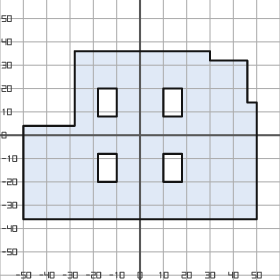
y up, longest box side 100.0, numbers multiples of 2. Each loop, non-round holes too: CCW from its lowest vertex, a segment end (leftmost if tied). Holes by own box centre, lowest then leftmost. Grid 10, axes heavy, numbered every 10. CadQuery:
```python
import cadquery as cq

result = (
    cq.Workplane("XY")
    .moveTo(-50.0, -36.0)
    .lineTo(50.0, -36.0)
    .lineTo(50.0, 14.0)
    .lineTo(46.0, 14.0)
    .lineTo(46.0, 32.0)
    .lineTo(30.0, 32.0)
    .lineTo(30.0, 36.0)
    .lineTo(-28.0, 36.0)
    .lineTo(-28.0, 4.0)
    .lineTo(-50.0, 4.0)
    .close()
    .moveTo(-18.0, -20.0)
    .lineTo(-10.0, -20.0)
    .lineTo(-10.0, -8.0)
    .lineTo(-18.0, -8.0)
    .close()
    .moveTo(10.0, -20.0)
    .lineTo(18.0, -20.0)
    .lineTo(18.0, -8.0)
    .lineTo(10.0, -8.0)
    .close()
    .moveTo(-18.0, 8.0)
    .lineTo(-10.0, 8.0)
    .lineTo(-10.0, 20.0)
    .lineTo(-18.0, 20.0)
    .close()
    .moveTo(10.0, 8.0)
    .lineTo(18.0, 8.0)
    .lineTo(18.0, 20.0)
    .lineTo(10.0, 20.0)
    .close()
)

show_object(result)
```